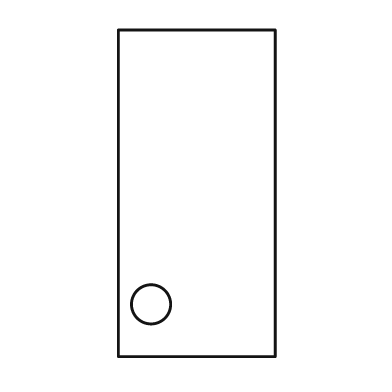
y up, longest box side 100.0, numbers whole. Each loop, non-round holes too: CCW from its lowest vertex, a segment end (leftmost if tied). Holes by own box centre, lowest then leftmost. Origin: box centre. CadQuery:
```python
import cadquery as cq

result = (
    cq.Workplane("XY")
    .moveTo(-24.0, -50.0)
    .lineTo(24.0, -50.0)
    .lineTo(24.0, 50.0)
    .lineTo(-24.0, 50.0)
    .close()
    .moveTo(-14.0, -34.0)
    .circle(6.0)
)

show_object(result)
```